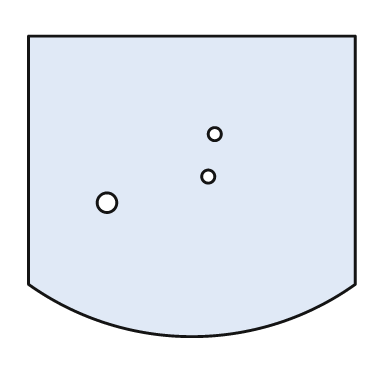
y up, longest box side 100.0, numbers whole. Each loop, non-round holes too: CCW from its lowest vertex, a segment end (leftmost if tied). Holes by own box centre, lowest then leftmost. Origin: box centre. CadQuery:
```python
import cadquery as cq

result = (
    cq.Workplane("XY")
    .moveTo(-50.0, -30.0)
    .threePointArc((0.0, -46.0), (50.0, -30.0))
    .lineTo(50.0, 46.0)
    .lineTo(-50.0, 46.0)
    .close()
    .moveTo(-26.0, -5.0)
    .circle(3.0)
    .moveTo(5.0, 3.0)
    .circle(2.0)
    .moveTo(7.0, 16.0)
    .circle(2.0)
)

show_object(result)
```